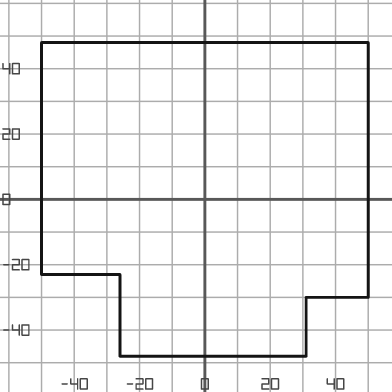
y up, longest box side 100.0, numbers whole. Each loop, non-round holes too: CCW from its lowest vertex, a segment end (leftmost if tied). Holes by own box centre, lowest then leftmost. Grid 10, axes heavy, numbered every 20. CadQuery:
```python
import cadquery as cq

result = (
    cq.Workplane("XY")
    .moveTo(-26.0, -48.0)
    .lineTo(31.0, -48.0)
    .lineTo(31.0, -30.0)
    .lineTo(50.0, -30.0)
    .lineTo(50.0, 48.0)
    .lineTo(-50.0, 48.0)
    .lineTo(-50.0, -23.0)
    .lineTo(-26.0, -23.0)
    .close()
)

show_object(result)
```